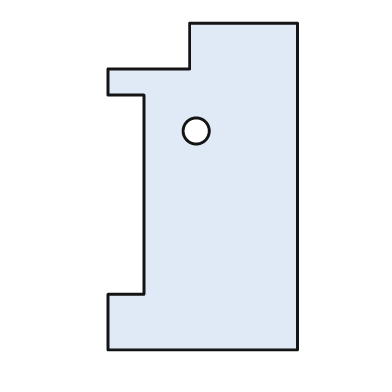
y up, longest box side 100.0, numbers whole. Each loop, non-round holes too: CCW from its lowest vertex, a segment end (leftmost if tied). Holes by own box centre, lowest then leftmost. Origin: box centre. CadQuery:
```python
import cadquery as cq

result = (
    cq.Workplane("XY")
    .moveTo(-29.0, -50.0)
    .lineTo(29.0, -50.0)
    .lineTo(29.0, 50.0)
    .lineTo(-4.0, 50.0)
    .lineTo(-4.0, 36.0)
    .lineTo(-29.0, 36.0)
    .lineTo(-29.0, 28.0)
    .lineTo(-18.0, 28.0)
    .lineTo(-18.0, -33.0)
    .lineTo(-29.0, -33.0)
    .close()
    .moveTo(-2.0, 17.0)
    .circle(4.0)
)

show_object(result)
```